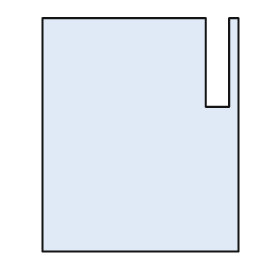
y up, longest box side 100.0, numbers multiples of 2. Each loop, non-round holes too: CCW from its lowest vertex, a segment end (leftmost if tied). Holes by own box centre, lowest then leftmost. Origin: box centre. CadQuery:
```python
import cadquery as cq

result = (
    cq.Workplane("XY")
    .moveTo(-42.0, -50.0)
    .lineTo(42.0, -50.0)
    .lineTo(42.0, 50.0)
    .lineTo(38.0, 50.0)
    .lineTo(38.0, 12.0)
    .lineTo(28.0, 12.0)
    .lineTo(28.0, 50.0)
    .lineTo(-42.0, 50.0)
    .close()
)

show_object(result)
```